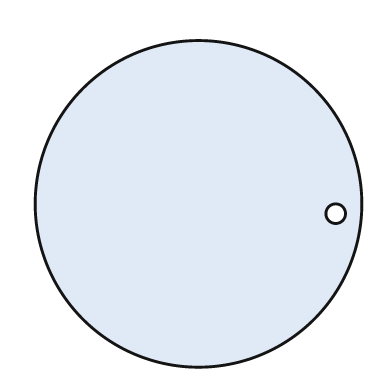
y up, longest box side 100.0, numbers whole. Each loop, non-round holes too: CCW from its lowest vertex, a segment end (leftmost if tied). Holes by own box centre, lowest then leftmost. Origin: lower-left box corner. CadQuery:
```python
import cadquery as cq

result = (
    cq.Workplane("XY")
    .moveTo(50.0, 50.0)
    .circle(50.0)
    .moveTo(92.0, 47.0)
    .circle(3.0)
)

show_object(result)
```